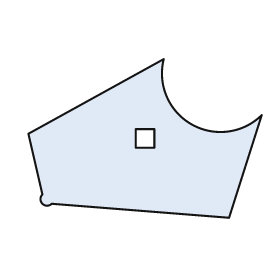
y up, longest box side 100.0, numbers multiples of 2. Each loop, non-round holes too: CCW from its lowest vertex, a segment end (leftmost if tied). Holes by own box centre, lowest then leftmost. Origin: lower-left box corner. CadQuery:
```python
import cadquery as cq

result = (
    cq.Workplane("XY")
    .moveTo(86.0, 0.0)
    .lineTo(100.0, 44.0)
    .threePointArc((70.0, 40.0), (58.0, 68.0))
    .lineTo(0.0, 36.0)
    .lineTo(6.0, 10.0)
    .threePointArc((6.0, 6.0), (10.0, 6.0))
    .close()
    .moveTo(46.0, 30.0)
    .lineTo(54.0, 30.0)
    .lineTo(54.0, 38.0)
    .lineTo(46.0, 38.0)
    .close()
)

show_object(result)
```